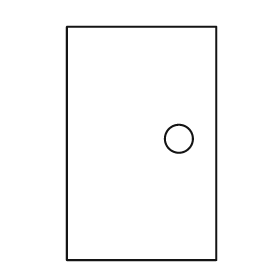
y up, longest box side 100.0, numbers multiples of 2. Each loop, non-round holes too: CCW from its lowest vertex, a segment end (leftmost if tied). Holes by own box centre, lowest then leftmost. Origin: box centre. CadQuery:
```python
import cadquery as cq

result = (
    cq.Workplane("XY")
    .moveTo(-32.0, -50.0)
    .lineTo(32.0, -50.0)
    .lineTo(32.0, 50.0)
    .lineTo(-32.0, 50.0)
    .close()
    .moveTo(16.0, 2.0)
    .circle(6.0)
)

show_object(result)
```